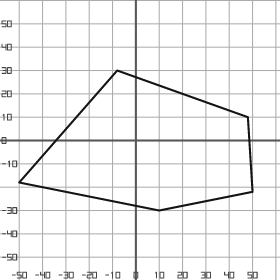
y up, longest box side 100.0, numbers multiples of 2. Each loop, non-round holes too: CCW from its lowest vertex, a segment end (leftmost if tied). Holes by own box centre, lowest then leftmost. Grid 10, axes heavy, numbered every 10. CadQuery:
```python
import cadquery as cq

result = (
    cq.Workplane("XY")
    .moveTo(10.0, -30.0)
    .lineTo(50.0, -22.0)
    .lineTo(48.0, 10.0)
    .lineTo(-8.0, 30.0)
    .lineTo(-50.0, -18.0)
    .close()
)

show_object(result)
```